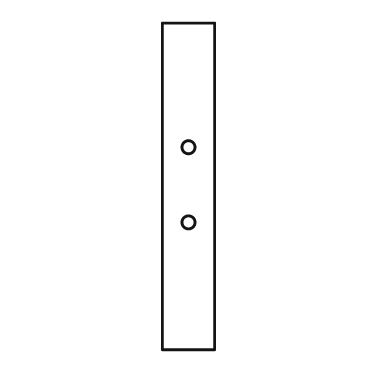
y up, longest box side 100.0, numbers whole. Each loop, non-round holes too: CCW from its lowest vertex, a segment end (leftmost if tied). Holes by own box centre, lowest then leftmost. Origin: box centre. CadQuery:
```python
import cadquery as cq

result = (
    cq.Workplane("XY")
    .moveTo(-8.0, -50.0)
    .lineTo(8.0, -50.0)
    .lineTo(8.0, 50.0)
    .lineTo(-8.0, 50.0)
    .close()
    .moveTo(0.0, -11.0)
    .circle(2.0)
    .moveTo(0.0, 12.0)
    .circle(2.0)
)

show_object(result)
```